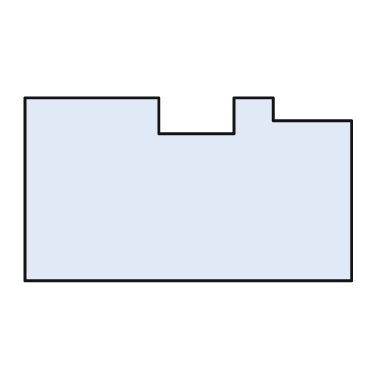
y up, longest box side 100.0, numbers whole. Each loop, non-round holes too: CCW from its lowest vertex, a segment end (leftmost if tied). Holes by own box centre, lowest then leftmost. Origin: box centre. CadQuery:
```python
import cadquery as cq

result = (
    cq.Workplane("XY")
    .moveTo(-50.0, -28.0)
    .lineTo(50.0, -28.0)
    .lineTo(50.0, 21.0)
    .lineTo(26.0, 21.0)
    .lineTo(26.0, 28.0)
    .lineTo(14.0, 28.0)
    .lineTo(14.0, 17.0)
    .lineTo(-9.0, 17.0)
    .lineTo(-9.0, 28.0)
    .lineTo(-50.0, 28.0)
    .close()
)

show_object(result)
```